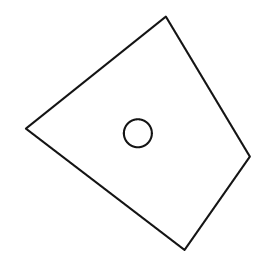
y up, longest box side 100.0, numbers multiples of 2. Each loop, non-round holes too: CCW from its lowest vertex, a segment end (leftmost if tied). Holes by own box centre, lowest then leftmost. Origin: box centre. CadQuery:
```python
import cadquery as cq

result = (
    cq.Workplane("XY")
    .moveTo(20.0, -50.0)
    .lineTo(48.0, -10.0)
    .lineTo(12.0, 50.0)
    .lineTo(-48.0, 2.0)
    .close()
    .moveTo(0.0, 0.0)
    .circle(6.0)
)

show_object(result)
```